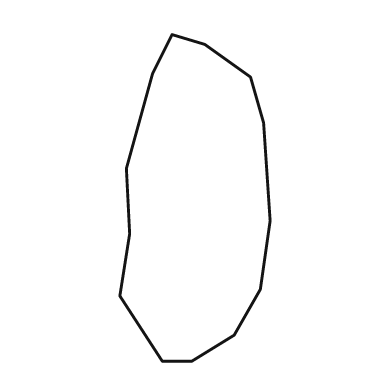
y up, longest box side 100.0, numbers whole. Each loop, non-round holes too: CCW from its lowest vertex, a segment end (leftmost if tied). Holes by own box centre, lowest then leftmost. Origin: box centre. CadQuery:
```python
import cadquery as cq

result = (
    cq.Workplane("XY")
    .moveTo(-10.0, -50.0)
    .lineTo(-1.0, -50.0)
    .lineTo(12.0, -42.0)
    .lineTo(20.0, -28.0)
    .lineTo(23.0, -7.0)
    .lineTo(21.0, 23.0)
    .lineTo(17.0, 37.0)
    .lineTo(3.0, 47.0)
    .lineTo(-7.0, 50.0)
    .lineTo(-13.0, 38.0)
    .lineTo(-21.0, 9.0)
    .lineTo(-20.0, -11.0)
    .lineTo(-23.0, -30.0)
    .close()
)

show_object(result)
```